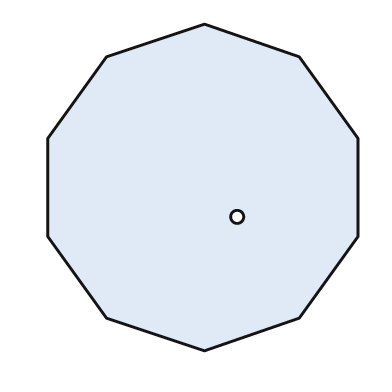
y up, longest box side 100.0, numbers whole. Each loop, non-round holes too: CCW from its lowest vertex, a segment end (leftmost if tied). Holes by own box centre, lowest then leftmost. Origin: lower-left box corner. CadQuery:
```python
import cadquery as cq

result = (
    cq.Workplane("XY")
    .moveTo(48.0, 0.0)
    .lineTo(77.0, 10.0)
    .lineTo(95.0, 35.0)
    .lineTo(95.0, 65.0)
    .lineTo(77.0, 90.0)
    .lineTo(48.0, 100.0)
    .lineTo(18.0, 90.0)
    .lineTo(0.0, 65.0)
    .lineTo(0.0, 35.0)
    .lineTo(18.0, 10.0)
    .close()
    .moveTo(58.0, 41.0)
    .circle(2.0)
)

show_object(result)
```